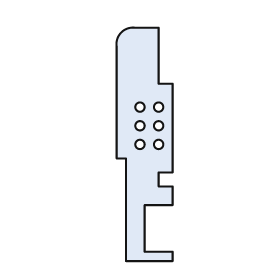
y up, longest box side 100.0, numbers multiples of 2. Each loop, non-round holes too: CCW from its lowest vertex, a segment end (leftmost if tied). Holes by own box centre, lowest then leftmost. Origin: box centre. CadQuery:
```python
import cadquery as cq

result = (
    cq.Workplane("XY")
    .moveTo(-8.0, -50.0)
    .lineTo(12.0, -50.0)
    .lineTo(12.0, -46.0)
    .lineTo(0.0, -46.0)
    .lineTo(0.0, -26.0)
    .lineTo(12.0, -26.0)
    .lineTo(12.0, -18.0)
    .lineTo(6.0, -18.0)
    .lineTo(6.0, -12.0)
    .lineTo(12.0, -12.0)
    .lineTo(12.0, 26.0)
    .lineTo(6.0, 26.0)
    .lineTo(6.0, 50.0)
    .lineTo(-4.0, 50.0)
    .threePointArc((-10.0, 48.0), (-12.0, 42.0))
    .lineTo(-12.0, -6.0)
    .lineTo(-8.0, -6.0)
    .close()
    .moveTo(-2.0, 0.0)
    .circle(2.0)
    .moveTo(6.0, 0.0)
    .circle(2.0)
    .moveTo(-2.0, 8.0)
    .circle(2.0)
    .moveTo(6.0, 8.0)
    .circle(2.0)
    .moveTo(-2.0, 16.0)
    .circle(2.0)
    .moveTo(6.0, 16.0)
    .circle(2.0)
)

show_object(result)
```